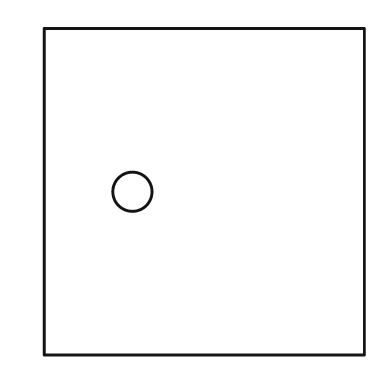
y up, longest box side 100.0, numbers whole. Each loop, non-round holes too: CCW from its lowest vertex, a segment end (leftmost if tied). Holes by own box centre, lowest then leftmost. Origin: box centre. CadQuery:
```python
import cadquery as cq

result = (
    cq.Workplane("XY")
    .moveTo(-49.0, -50.0)
    .lineTo(49.0, -50.0)
    .lineTo(49.0, 50.0)
    .lineTo(-49.0, 50.0)
    .close()
    .moveTo(-22.0, 0.0)
    .circle(6.0)
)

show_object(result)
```